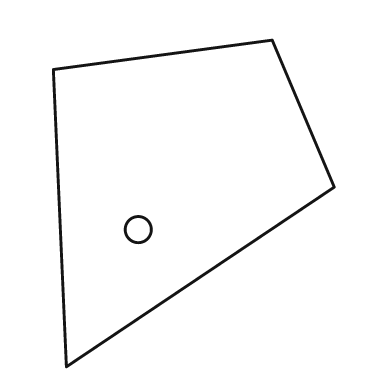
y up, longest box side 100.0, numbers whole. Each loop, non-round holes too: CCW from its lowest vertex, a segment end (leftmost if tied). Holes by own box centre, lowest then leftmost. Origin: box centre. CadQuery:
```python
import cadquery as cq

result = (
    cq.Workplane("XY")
    .moveTo(-39.0, -50.0)
    .lineTo(43.0, 5.0)
    .lineTo(24.0, 50.0)
    .lineTo(-43.0, 41.0)
    .close()
    .moveTo(-17.0, -8.0)
    .circle(4.0)
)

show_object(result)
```